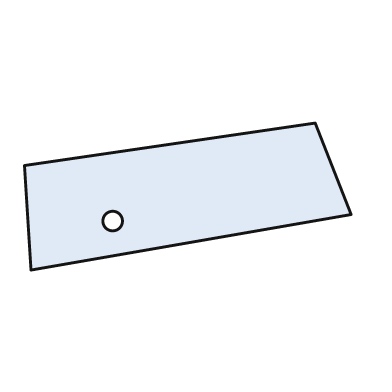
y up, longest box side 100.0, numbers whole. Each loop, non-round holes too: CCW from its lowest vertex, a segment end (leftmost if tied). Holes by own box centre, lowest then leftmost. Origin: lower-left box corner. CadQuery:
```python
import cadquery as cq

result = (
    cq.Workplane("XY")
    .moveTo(2.0, 0.0)
    .lineTo(100.0, 17.0)
    .lineTo(89.0, 45.0)
    .lineTo(0.0, 32.0)
    .close()
    .moveTo(27.0, 15.0)
    .circle(3.0)
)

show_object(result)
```